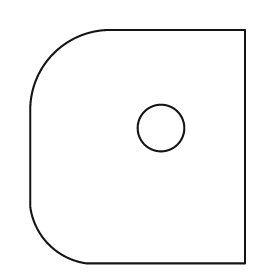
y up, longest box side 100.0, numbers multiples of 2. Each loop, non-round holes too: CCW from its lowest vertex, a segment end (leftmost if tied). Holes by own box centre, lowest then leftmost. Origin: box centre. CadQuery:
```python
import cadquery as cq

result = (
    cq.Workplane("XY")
    .moveTo(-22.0, -50.0)
    .lineTo(46.0, -50.0)
    .lineTo(46.0, 50.0)
    .lineTo(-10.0, 50.0)
    .threePointArc((-36.0, 40.0), (-46.0, 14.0))
    .lineTo(-46.0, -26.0)
    .threePointArc((-38.0, -42.0), (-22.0, -50.0))
    .close()
    .moveTo(10.0, 8.0)
    .circle(10.0)
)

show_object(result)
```